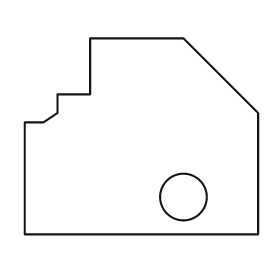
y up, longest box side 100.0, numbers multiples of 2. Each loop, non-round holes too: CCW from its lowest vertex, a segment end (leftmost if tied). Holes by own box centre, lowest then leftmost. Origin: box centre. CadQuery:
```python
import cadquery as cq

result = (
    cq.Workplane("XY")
    .moveTo(-50.0, -42.0)
    .lineTo(50.0, -42.0)
    .lineTo(50.0, 10.0)
    .lineTo(18.0, 42.0)
    .lineTo(-22.0, 42.0)
    .lineTo(-22.0, 18.0)
    .lineTo(-36.0, 18.0)
    .lineTo(-36.0, 10.0)
    .lineTo(-42.0, 6.0)
    .lineTo(-50.0, 6.0)
    .close()
    .moveTo(18.0, -26.0)
    .circle(10.0)
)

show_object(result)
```